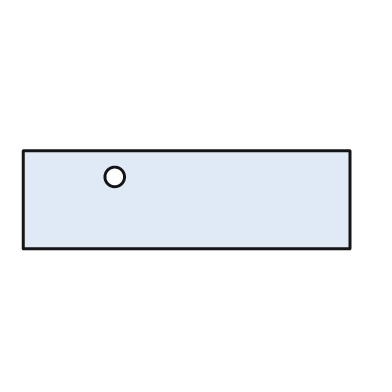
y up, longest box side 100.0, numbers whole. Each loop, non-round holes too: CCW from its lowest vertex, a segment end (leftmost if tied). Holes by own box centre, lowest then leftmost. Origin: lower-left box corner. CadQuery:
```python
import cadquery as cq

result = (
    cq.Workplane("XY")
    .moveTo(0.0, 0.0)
    .lineTo(100.0, 0.0)
    .lineTo(100.0, 30.0)
    .lineTo(0.0, 30.0)
    .close()
    .moveTo(28.0, 22.0)
    .circle(3.0)
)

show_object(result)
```